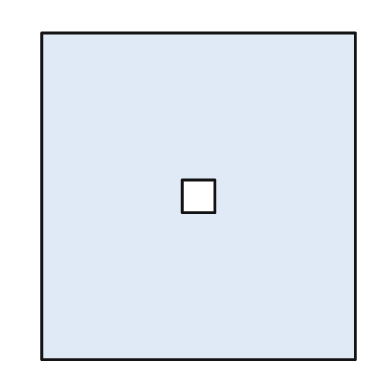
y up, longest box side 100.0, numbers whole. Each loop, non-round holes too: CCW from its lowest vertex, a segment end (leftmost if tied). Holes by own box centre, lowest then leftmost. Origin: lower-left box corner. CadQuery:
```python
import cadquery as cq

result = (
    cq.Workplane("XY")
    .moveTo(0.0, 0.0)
    .lineTo(96.0, 0.0)
    .lineTo(96.0, 100.0)
    .lineTo(0.0, 100.0)
    .close()
    .moveTo(43.0, 45.0)
    .lineTo(53.0, 45.0)
    .lineTo(53.0, 55.0)
    .lineTo(43.0, 55.0)
    .close()
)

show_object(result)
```